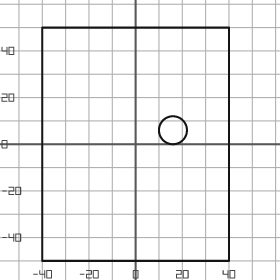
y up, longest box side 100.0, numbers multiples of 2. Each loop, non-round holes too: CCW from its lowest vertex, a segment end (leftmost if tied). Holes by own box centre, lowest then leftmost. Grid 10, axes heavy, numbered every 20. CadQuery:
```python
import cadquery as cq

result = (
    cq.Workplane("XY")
    .moveTo(-40.0, -50.0)
    .lineTo(40.0, -50.0)
    .lineTo(40.0, 50.0)
    .lineTo(-40.0, 50.0)
    .close()
    .moveTo(16.0, 6.0)
    .circle(6.0)
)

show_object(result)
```